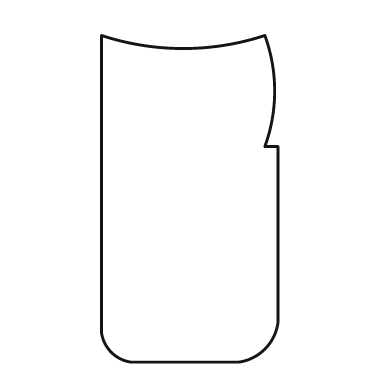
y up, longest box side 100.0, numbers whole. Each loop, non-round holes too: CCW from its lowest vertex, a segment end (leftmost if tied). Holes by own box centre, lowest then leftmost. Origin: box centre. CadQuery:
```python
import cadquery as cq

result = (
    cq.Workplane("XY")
    .moveTo(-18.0, -50.0)
    .lineTo(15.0, -50.0)
    .threePointArc((23.0, -46.0), (27.0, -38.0))
    .lineTo(27.0, 16.0)
    .lineTo(23.0, 16.0)
    .threePointArc((26.0, 33.0), (23.0, 50.0))
    .threePointArc((-2.0, 46.0), (-27.0, 50.0))
    .lineTo(-27.0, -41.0)
    .threePointArc((-24.0, -47.0), (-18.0, -50.0))
    .close()
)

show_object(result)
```